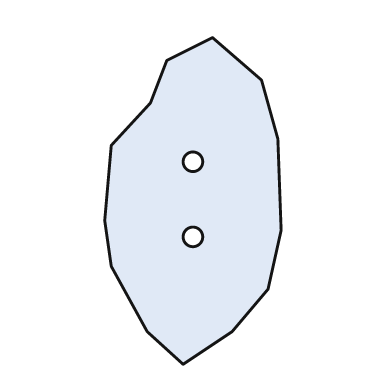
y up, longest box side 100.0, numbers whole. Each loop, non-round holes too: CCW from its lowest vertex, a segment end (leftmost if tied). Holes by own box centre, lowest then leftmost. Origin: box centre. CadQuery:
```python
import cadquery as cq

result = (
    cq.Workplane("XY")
    .moveTo(-3.0, -50.0)
    .lineTo(12.0, -40.0)
    .lineTo(23.0, -27.0)
    .lineTo(27.0, -9.0)
    .lineTo(26.0, 19.0)
    .lineTo(21.0, 37.0)
    .lineTo(6.0, 50.0)
    .lineTo(-8.0, 43.0)
    .lineTo(-13.0, 30.0)
    .lineTo(-25.0, 17.0)
    .lineTo(-27.0, -6.0)
    .lineTo(-25.0, -20.0)
    .lineTo(-14.0, -40.0)
    .close()
    .moveTo(0.0, -11.0)
    .circle(3.0)
    .moveTo(0.0, 12.0)
    .circle(3.0)
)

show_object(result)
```